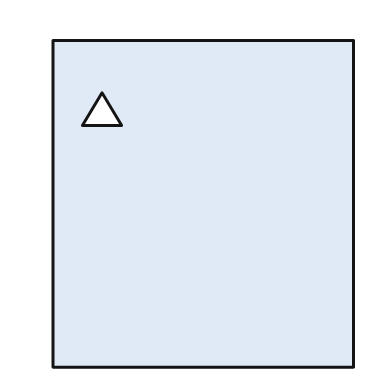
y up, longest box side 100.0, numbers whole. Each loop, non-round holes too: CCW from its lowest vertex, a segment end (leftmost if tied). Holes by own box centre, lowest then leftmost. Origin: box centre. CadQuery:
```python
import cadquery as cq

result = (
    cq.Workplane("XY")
    .moveTo(-46.0, -50.0)
    .lineTo(46.0, -50.0)
    .lineTo(46.0, 50.0)
    .lineTo(-46.0, 50.0)
    .close()
    .moveTo(-37.0, 24.0)
    .lineTo(-25.0, 24.0)
    .lineTo(-31.0, 34.0)
    .close()
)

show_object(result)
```